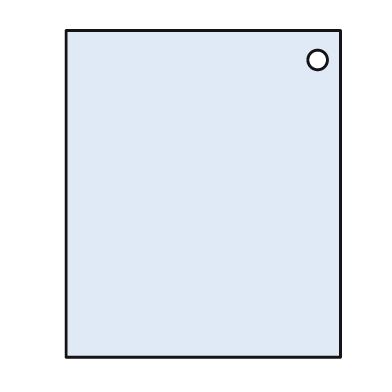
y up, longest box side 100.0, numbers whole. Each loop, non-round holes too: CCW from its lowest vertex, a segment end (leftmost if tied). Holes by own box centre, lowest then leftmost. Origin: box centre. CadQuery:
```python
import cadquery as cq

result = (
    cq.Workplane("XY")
    .moveTo(-42.0, -50.0)
    .lineTo(42.0, -50.0)
    .lineTo(42.0, 50.0)
    .lineTo(-42.0, 50.0)
    .close()
    .moveTo(35.0, 41.0)
    .circle(3.0)
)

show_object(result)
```